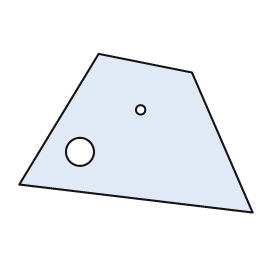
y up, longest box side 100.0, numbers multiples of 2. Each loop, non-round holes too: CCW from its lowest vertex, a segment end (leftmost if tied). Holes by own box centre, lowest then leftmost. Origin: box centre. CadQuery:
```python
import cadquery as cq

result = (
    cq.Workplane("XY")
    .moveTo(50.0, -34.0)
    .lineTo(24.0, 26.0)
    .lineTo(-16.0, 34.0)
    .lineTo(-50.0, -22.0)
    .close()
    .moveTo(-24.0, -8.0)
    .circle(6.0)
    .moveTo(2.0, 10.0)
    .circle(2.0)
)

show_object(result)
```